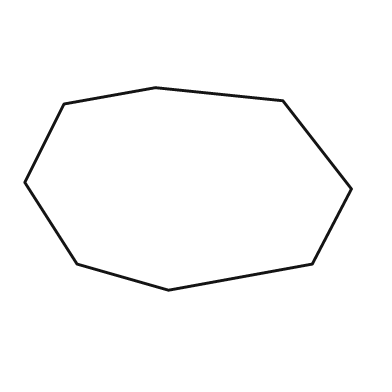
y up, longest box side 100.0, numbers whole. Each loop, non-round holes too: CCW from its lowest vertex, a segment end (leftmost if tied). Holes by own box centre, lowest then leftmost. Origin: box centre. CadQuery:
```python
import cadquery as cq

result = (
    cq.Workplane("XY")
    .moveTo(-6.0, -31.0)
    .lineTo(38.0, -23.0)
    .lineTo(50.0, 0.0)
    .lineTo(29.0, 27.0)
    .lineTo(-10.0, 31.0)
    .lineTo(-38.0, 26.0)
    .lineTo(-50.0, 2.0)
    .lineTo(-34.0, -23.0)
    .close()
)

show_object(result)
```